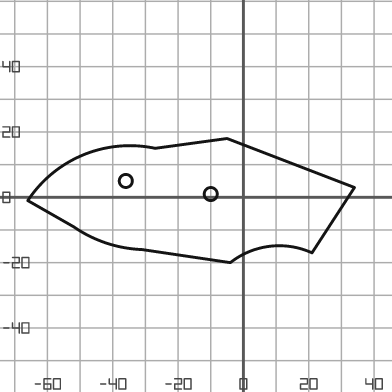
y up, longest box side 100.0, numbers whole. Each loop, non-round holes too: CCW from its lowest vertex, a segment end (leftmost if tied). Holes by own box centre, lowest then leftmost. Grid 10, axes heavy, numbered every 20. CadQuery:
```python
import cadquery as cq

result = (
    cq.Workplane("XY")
    .moveTo(-4.0, -20.0)
    .threePointArc((8.0, -15.0), (21.0, -17.0))
    .lineTo(34.0, 3.0)
    .lineTo(-5.0, 18.0)
    .lineTo(-27.0, 15.0)
    .threePointArc((-49.0, 13.0), (-66.0, -1.0))
    .lineTo(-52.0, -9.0)
    .threePointArc((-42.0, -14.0), (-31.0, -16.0))
    .close()
    .moveTo(-10.0, 1.0)
    .circle(2.0)
    .moveTo(-36.0, 5.0)
    .circle(2.0)
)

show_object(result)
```